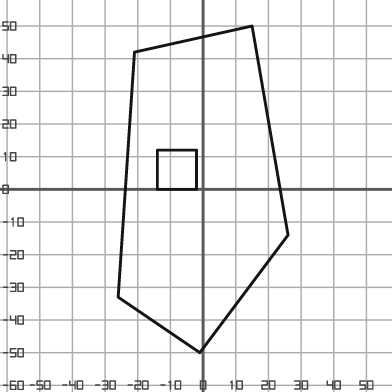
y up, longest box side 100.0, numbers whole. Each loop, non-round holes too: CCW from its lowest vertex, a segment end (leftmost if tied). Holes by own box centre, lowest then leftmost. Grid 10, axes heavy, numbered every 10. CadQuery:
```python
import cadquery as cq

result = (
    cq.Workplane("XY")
    .moveTo(-1.0, -50.0)
    .lineTo(26.0, -14.0)
    .lineTo(15.0, 50.0)
    .lineTo(-21.0, 42.0)
    .lineTo(-26.0, -33.0)
    .close()
    .moveTo(-14.0, 0.0)
    .lineTo(-2.0, 0.0)
    .lineTo(-2.0, 12.0)
    .lineTo(-14.0, 12.0)
    .close()
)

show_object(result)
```